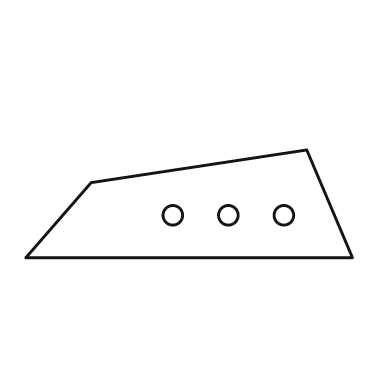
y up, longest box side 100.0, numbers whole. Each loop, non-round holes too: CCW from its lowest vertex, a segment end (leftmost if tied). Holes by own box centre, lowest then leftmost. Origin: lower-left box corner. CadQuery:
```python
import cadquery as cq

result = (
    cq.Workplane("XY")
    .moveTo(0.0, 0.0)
    .lineTo(100.0, 0.0)
    .lineTo(86.0, 33.0)
    .lineTo(20.0, 23.0)
    .close()
    .moveTo(45.0, 13.0)
    .circle(3.0)
    .moveTo(62.0, 13.0)
    .circle(3.0)
    .moveTo(79.0, 13.0)
    .circle(3.0)
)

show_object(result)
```